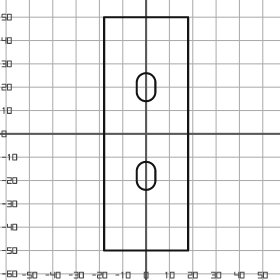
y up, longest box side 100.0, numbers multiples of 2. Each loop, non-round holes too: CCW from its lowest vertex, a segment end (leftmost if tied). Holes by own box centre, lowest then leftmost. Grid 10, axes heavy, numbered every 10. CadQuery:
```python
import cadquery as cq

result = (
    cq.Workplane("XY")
    .moveTo(-18.0, -50.0)
    .lineTo(18.0, -50.0)
    .lineTo(18.0, 50.0)
    .lineTo(-18.0, 50.0)
    .close()
    .moveTo(-4.0, -20.0)
    .threePointArc((0.0, -24.0), (4.0, -20.0))
    .lineTo(4.0, -16.0)
    .threePointArc((0.0, -12.0), (-4.0, -16.0))
    .close()
    .moveTo(-4.0, 18.0)
    .threePointArc((0.0, 14.0), (4.0, 18.0))
    .lineTo(4.0, 22.0)
    .threePointArc((0.0, 26.0), (-4.0, 22.0))
    .close()
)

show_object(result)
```